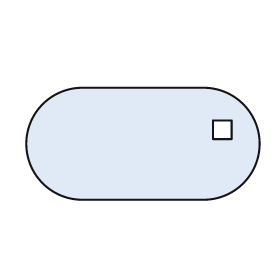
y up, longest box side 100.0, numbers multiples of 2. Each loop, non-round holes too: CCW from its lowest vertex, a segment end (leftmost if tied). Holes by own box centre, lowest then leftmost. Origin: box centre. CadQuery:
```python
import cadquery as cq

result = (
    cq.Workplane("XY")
    .moveTo(-26.0, -24.0)
    .lineTo(26.0, -24.0)
    .threePointArc((50.0, 0.0), (26.0, 24.0))
    .lineTo(-26.0, 24.0)
    .threePointArc((-50.0, 0.0), (-26.0, -24.0))
    .close()
    .moveTo(30.0, 2.0)
    .lineTo(38.0, 2.0)
    .lineTo(38.0, 10.0)
    .lineTo(30.0, 10.0)
    .close()
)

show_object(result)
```